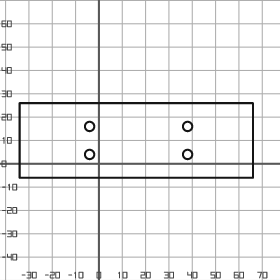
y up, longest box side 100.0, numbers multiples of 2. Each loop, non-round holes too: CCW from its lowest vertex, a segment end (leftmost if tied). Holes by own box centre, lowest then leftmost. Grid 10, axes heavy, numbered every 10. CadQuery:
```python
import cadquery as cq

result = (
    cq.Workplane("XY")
    .moveTo(-34.0, -6.0)
    .lineTo(66.0, -6.0)
    .lineTo(66.0, 26.0)
    .lineTo(-34.0, 26.0)
    .close()
    .moveTo(-4.0, 4.0)
    .circle(2.0)
    .moveTo(38.0, 4.0)
    .circle(2.0)
    .moveTo(-4.0, 16.0)
    .circle(2.0)
    .moveTo(38.0, 16.0)
    .circle(2.0)
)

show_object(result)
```